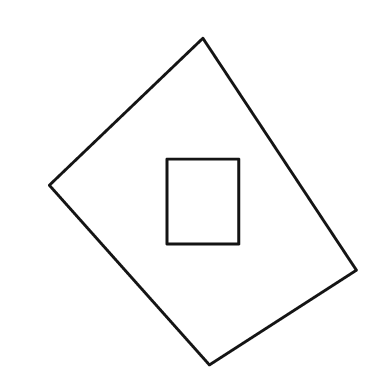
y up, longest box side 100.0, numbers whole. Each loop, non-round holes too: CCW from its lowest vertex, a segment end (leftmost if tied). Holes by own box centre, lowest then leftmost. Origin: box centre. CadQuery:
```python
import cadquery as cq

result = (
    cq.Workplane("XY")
    .moveTo(2.0, -50.0)
    .lineTo(47.0, -21.0)
    .lineTo(0.0, 50.0)
    .lineTo(-47.0, 5.0)
    .close()
    .moveTo(-11.0, -13.0)
    .lineTo(11.0, -13.0)
    .lineTo(11.0, 13.0)
    .lineTo(-11.0, 13.0)
    .close()
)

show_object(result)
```